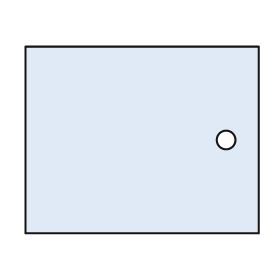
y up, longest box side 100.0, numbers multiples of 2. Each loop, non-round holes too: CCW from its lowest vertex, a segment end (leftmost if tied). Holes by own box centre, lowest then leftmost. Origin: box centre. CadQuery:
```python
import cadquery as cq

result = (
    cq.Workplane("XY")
    .moveTo(-50.0, -40.0)
    .lineTo(50.0, -40.0)
    .lineTo(50.0, 40.0)
    .lineTo(-50.0, 40.0)
    .close()
    .moveTo(36.0, 0.0)
    .circle(4.0)
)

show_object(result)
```